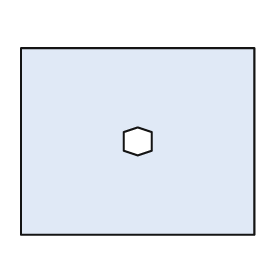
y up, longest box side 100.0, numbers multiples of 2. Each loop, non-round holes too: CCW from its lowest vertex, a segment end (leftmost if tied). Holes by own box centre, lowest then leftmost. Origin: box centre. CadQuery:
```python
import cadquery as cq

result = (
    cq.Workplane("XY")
    .moveTo(-50.0, -40.0)
    .lineTo(50.0, -40.0)
    .lineTo(50.0, 40.0)
    .lineTo(-50.0, 40.0)
    .close()
    .moveTo(0.0, -6.0)
    .lineTo(6.0, -4.0)
    .lineTo(6.0, 4.0)
    .lineTo(0.0, 6.0)
    .lineTo(-6.0, 4.0)
    .lineTo(-6.0, -4.0)
    .close()
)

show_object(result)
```